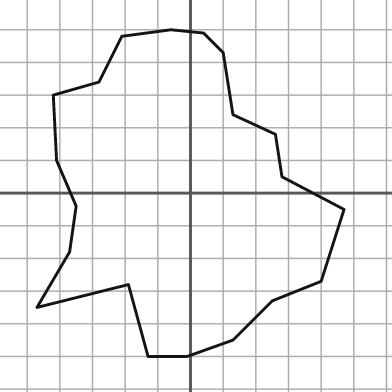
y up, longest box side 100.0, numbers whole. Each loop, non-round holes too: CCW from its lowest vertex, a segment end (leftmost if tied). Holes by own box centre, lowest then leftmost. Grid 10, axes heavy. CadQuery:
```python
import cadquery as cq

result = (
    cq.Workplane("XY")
    .moveTo(-13.0, -50.0)
    .lineTo(-1.0, -50.0)
    .lineTo(13.0, -45.0)
    .lineTo(25.0, -33.0)
    .lineTo(40.0, -27.0)
    .lineTo(47.0, -5.0)
    .lineTo(28.0, 5.0)
    .lineTo(26.0, 18.0)
    .lineTo(13.0, 24.0)
    .lineTo(10.0, 43.0)
    .lineTo(4.0, 49.0)
    .lineTo(-6.0, 50.0)
    .lineTo(-21.0, 48.0)
    .lineTo(-28.0, 34.0)
    .lineTo(-42.0, 30.0)
    .lineTo(-41.0, 10.0)
    .lineTo(-35.0, -4.0)
    .lineTo(-37.0, -18.0)
    .lineTo(-47.0, -35.0)
    .lineTo(-19.0, -28.0)
    .close()
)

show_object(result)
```